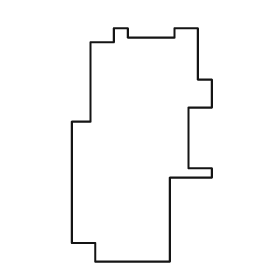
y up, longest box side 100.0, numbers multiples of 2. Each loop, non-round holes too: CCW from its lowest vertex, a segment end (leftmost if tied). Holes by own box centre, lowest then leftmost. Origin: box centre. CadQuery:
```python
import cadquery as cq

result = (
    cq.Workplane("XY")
    .moveTo(-20.0, -50.0)
    .lineTo(12.0, -50.0)
    .lineTo(12.0, -14.0)
    .lineTo(30.0, -14.0)
    .lineTo(30.0, -10.0)
    .lineTo(20.0, -10.0)
    .lineTo(20.0, 16.0)
    .lineTo(30.0, 16.0)
    .lineTo(30.0, 28.0)
    .lineTo(24.0, 28.0)
    .lineTo(24.0, 50.0)
    .lineTo(14.0, 50.0)
    .lineTo(14.0, 46.0)
    .lineTo(-6.0, 46.0)
    .lineTo(-6.0, 50.0)
    .lineTo(-12.0, 50.0)
    .lineTo(-12.0, 44.0)
    .lineTo(-22.0, 44.0)
    .lineTo(-22.0, 10.0)
    .lineTo(-30.0, 10.0)
    .lineTo(-30.0, -42.0)
    .lineTo(-20.0, -42.0)
    .close()
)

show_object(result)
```